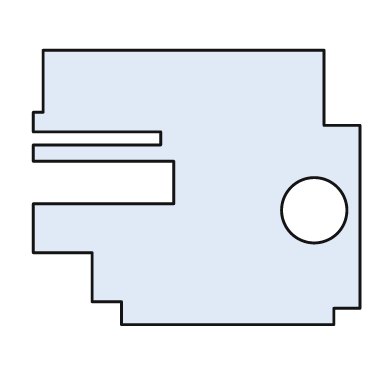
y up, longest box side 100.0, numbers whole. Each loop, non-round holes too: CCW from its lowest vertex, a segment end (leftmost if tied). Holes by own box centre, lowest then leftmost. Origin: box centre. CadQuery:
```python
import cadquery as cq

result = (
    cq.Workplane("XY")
    .moveTo(-23.0, -42.0)
    .lineTo(42.0, -42.0)
    .lineTo(42.0, -37.0)
    .lineTo(50.0, -37.0)
    .lineTo(50.0, 19.0)
    .lineTo(39.0, 19.0)
    .lineTo(39.0, 42.0)
    .lineTo(-47.0, 42.0)
    .lineTo(-47.0, 23.0)
    .lineTo(-50.0, 23.0)
    .lineTo(-50.0, 17.0)
    .lineTo(-11.0, 17.0)
    .lineTo(-11.0, 13.0)
    .lineTo(-50.0, 13.0)
    .lineTo(-50.0, 8.0)
    .lineTo(-7.0, 8.0)
    .lineTo(-7.0, -5.0)
    .lineTo(-50.0, -5.0)
    .lineTo(-50.0, -20.0)
    .lineTo(-32.0, -20.0)
    .lineTo(-32.0, -35.0)
    .lineTo(-23.0, -35.0)
    .close()
    .moveTo(36.0, -7.0)
    .circle(10.0)
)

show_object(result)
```